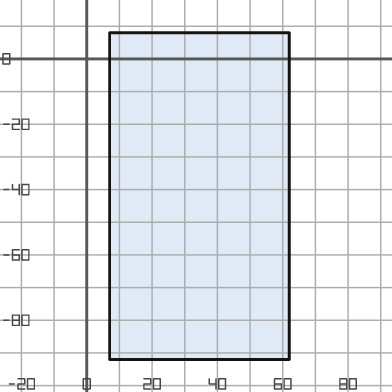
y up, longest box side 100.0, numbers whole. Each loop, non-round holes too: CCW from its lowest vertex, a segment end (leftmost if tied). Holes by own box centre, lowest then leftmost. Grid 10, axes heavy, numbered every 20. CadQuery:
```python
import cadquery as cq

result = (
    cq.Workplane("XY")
    .moveTo(7.0, -92.0)
    .lineTo(62.0, -92.0)
    .lineTo(62.0, 8.0)
    .lineTo(7.0, 8.0)
    .close()
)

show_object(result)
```